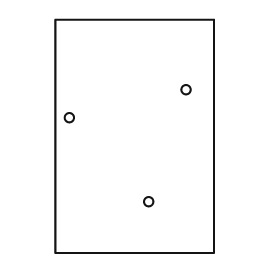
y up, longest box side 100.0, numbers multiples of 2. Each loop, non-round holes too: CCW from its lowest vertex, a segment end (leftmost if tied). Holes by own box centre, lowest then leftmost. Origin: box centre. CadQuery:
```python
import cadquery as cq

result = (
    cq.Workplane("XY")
    .moveTo(-34.0, -50.0)
    .lineTo(34.0, -50.0)
    .lineTo(34.0, 50.0)
    .lineTo(-34.0, 50.0)
    .close()
    .moveTo(6.0, -28.0)
    .circle(2.0)
    .moveTo(-28.0, 8.0)
    .circle(2.0)
    .moveTo(22.0, 20.0)
    .circle(2.0)
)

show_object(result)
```